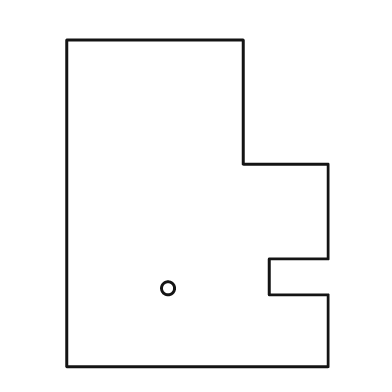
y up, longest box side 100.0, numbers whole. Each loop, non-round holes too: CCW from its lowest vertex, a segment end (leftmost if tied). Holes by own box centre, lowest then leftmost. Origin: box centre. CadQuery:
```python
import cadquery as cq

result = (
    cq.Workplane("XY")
    .moveTo(-40.0, -50.0)
    .lineTo(40.0, -50.0)
    .lineTo(40.0, -28.0)
    .lineTo(22.0, -28.0)
    .lineTo(22.0, -17.0)
    .lineTo(40.0, -17.0)
    .lineTo(40.0, 12.0)
    .lineTo(14.0, 12.0)
    .lineTo(14.0, 50.0)
    .lineTo(-40.0, 50.0)
    .close()
    .moveTo(-9.0, -26.0)
    .circle(2.0)
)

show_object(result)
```